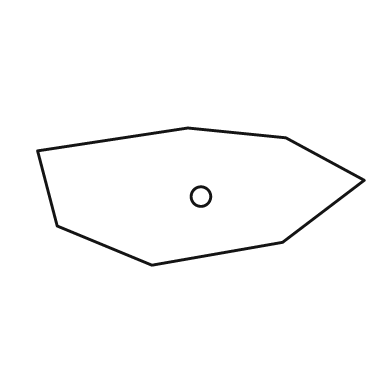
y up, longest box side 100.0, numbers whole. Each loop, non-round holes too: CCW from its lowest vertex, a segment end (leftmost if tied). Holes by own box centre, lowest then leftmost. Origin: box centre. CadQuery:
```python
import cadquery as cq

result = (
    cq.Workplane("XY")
    .moveTo(-15.0, -21.0)
    .lineTo(25.0, -14.0)
    .lineTo(50.0, 5.0)
    .lineTo(26.0, 18.0)
    .lineTo(-4.0, 21.0)
    .lineTo(-50.0, 14.0)
    .lineTo(-44.0, -9.0)
    .close()
    .moveTo(0.0, 0.0)
    .circle(3.0)
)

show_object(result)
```